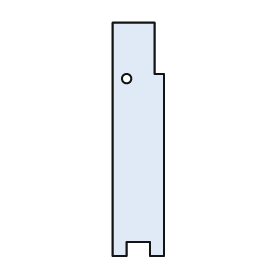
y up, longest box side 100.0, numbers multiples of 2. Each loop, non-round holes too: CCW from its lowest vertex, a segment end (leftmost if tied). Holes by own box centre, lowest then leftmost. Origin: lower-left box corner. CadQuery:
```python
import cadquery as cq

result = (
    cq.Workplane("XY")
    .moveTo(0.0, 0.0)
    .lineTo(6.0, 0.0)
    .lineTo(6.0, 6.0)
    .lineTo(16.0, 6.0)
    .lineTo(16.0, 0.0)
    .lineTo(22.0, 0.0)
    .lineTo(22.0, 78.0)
    .lineTo(18.0, 78.0)
    .lineTo(18.0, 100.0)
    .lineTo(0.0, 100.0)
    .close()
    .moveTo(6.0, 76.0)
    .circle(2.0)
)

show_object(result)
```